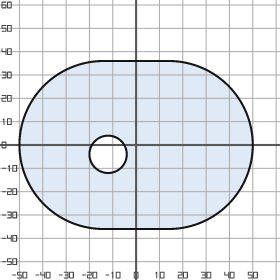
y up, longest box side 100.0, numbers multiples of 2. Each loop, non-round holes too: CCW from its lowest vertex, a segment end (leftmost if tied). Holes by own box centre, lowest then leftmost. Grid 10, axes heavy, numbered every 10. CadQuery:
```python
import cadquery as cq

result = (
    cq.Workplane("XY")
    .moveTo(-14.0, -36.0)
    .lineTo(14.0, -36.0)
    .threePointArc((50.0, 0.0), (14.0, 36.0))
    .lineTo(-14.0, 36.0)
    .threePointArc((-50.0, 0.0), (-14.0, -36.0))
    .close()
    .moveTo(-12.0, -4.0)
    .circle(8.0)
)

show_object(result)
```